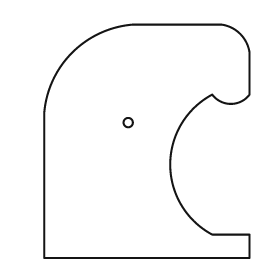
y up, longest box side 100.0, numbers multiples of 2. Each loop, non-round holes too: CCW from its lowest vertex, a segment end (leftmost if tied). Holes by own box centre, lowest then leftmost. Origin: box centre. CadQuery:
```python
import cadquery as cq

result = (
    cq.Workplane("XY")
    .moveTo(-44.0, -50.0)
    .lineTo(44.0, -50.0)
    .lineTo(44.0, -40.0)
    .lineTo(28.0, -40.0)
    .threePointArc((10.0, -10.0), (28.0, 20.0))
    .threePointArc((36.0, 16.0), (44.0, 20.0))
    .lineTo(44.0, 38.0)
    .threePointArc((40.0, 46.0), (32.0, 50.0))
    .lineTo(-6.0, 50.0)
    .threePointArc((-32.0, 38.0), (-44.0, 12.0))
    .close()
    .moveTo(-8.0, 8.0)
    .circle(2.0)
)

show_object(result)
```